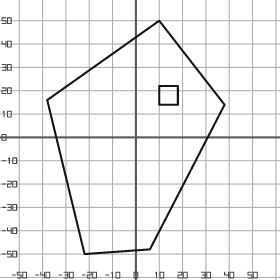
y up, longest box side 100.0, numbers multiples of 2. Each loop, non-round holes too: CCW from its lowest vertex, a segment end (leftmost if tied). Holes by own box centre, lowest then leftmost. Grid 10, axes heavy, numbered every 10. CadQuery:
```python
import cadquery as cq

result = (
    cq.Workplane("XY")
    .moveTo(-22.0, -50.0)
    .lineTo(6.0, -48.0)
    .lineTo(38.0, 14.0)
    .lineTo(10.0, 50.0)
    .lineTo(-38.0, 16.0)
    .close()
    .moveTo(10.0, 14.0)
    .lineTo(18.0, 14.0)
    .lineTo(18.0, 22.0)
    .lineTo(10.0, 22.0)
    .close()
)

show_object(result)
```